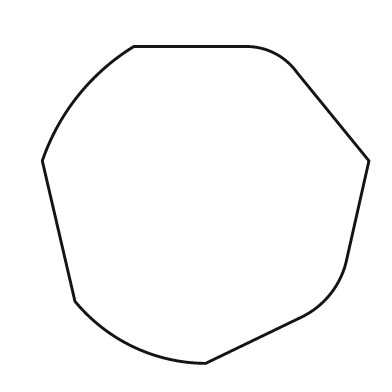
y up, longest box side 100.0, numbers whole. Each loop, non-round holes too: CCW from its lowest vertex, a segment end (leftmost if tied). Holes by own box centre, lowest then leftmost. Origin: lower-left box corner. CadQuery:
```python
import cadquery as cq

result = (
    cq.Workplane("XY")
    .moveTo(50.0, 0.0)
    .lineTo(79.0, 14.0)
    .threePointArc((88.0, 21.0), (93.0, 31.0))
    .lineTo(100.0, 62.0)
    .lineTo(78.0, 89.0)
    .threePointArc((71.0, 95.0), (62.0, 97.0))
    .lineTo(28.0, 97.0)
    .threePointArc((11.0, 82.0), (0.0, 62.0))
    .lineTo(10.0, 19.0)
    .threePointArc((28.0, 5.0), (50.0, 0.0))
    .close()
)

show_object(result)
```